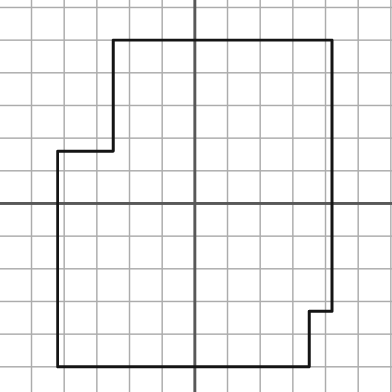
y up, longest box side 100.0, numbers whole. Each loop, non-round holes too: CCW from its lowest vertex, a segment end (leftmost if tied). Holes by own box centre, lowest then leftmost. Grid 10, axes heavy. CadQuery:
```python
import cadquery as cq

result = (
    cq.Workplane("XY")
    .moveTo(-42.0, -50.0)
    .lineTo(35.0, -50.0)
    .lineTo(35.0, -33.0)
    .lineTo(42.0, -33.0)
    .lineTo(42.0, 50.0)
    .lineTo(-25.0, 50.0)
    .lineTo(-25.0, 16.0)
    .lineTo(-42.0, 16.0)
    .close()
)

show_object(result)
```